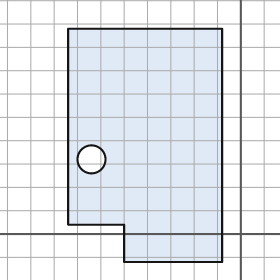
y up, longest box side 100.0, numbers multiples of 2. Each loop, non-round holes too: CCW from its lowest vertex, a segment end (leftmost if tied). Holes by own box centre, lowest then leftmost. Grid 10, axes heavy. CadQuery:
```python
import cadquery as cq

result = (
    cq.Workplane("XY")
    .moveTo(-50.0, -12.0)
    .lineTo(-8.0, -12.0)
    .lineTo(-8.0, 88.0)
    .lineTo(-74.0, 88.0)
    .lineTo(-74.0, 4.0)
    .lineTo(-50.0, 4.0)
    .close()
    .moveTo(-64.0, 32.0)
    .circle(6.0)
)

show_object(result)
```